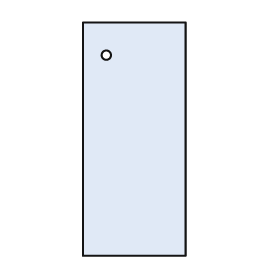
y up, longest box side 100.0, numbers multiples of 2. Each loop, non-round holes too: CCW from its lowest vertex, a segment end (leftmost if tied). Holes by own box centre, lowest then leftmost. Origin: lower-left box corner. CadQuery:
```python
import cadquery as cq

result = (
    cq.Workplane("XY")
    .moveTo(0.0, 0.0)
    .lineTo(44.0, 0.0)
    .lineTo(44.0, 100.0)
    .lineTo(0.0, 100.0)
    .close()
    .moveTo(10.0, 86.0)
    .circle(2.0)
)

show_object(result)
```